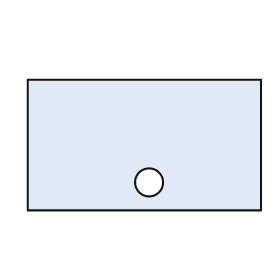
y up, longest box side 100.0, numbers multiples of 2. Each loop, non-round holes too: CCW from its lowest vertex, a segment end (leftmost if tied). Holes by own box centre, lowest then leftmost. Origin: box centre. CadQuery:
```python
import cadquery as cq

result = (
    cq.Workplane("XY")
    .moveTo(-50.0, -28.0)
    .lineTo(50.0, -28.0)
    .lineTo(50.0, 28.0)
    .lineTo(-50.0, 28.0)
    .close()
    .moveTo(2.0, -16.0)
    .circle(6.0)
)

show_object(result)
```